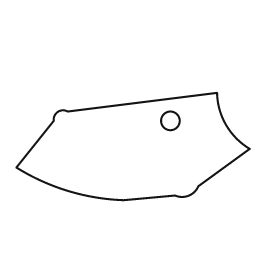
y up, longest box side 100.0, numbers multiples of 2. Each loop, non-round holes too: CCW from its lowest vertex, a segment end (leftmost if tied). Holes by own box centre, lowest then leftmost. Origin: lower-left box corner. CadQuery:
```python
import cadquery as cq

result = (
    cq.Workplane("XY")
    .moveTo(46.0, 0.0)
    .lineTo(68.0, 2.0)
    .threePointArc((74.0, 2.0), (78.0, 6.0))
    .lineTo(100.0, 22.0)
    .threePointArc((90.0, 32.0), (86.0, 46.0))
    .lineTo(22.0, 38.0)
    .threePointArc((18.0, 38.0), (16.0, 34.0))
    .lineTo(0.0, 14.0)
    .threePointArc((22.0, 4.0), (46.0, 0.0))
    .close()
    .moveTo(66.0, 34.0)
    .circle(4.0)
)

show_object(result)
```